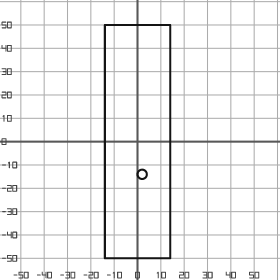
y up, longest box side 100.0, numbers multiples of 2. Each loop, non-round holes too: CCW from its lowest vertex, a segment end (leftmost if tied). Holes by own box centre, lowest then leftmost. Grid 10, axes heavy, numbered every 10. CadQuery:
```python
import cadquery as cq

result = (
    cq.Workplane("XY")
    .moveTo(-14.0, -50.0)
    .lineTo(14.0, -50.0)
    .lineTo(14.0, 50.0)
    .lineTo(-14.0, 50.0)
    .close()
    .moveTo(2.0, -14.0)
    .circle(2.0)
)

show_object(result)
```